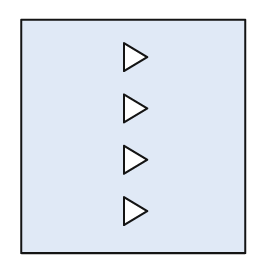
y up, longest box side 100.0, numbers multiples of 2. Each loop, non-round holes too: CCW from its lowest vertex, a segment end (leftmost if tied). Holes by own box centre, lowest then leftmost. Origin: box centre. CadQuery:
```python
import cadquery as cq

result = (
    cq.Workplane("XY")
    .moveTo(-48.0, -50.0)
    .lineTo(48.0, -50.0)
    .lineTo(48.0, 50.0)
    .lineTo(-48.0, 50.0)
    .close()
    .moveTo(-4.0, -38.0)
    .lineTo(6.0, -32.0)
    .lineTo(-4.0, -26.0)
    .close()
    .moveTo(-4.0, -16.0)
    .lineTo(6.0, -10.0)
    .lineTo(-4.0, -4.0)
    .close()
    .moveTo(-4.0, 6.0)
    .lineTo(6.0, 12.0)
    .lineTo(-4.0, 18.0)
    .close()
    .moveTo(-4.0, 28.0)
    .lineTo(6.0, 34.0)
    .lineTo(-4.0, 40.0)
    .close()
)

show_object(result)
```